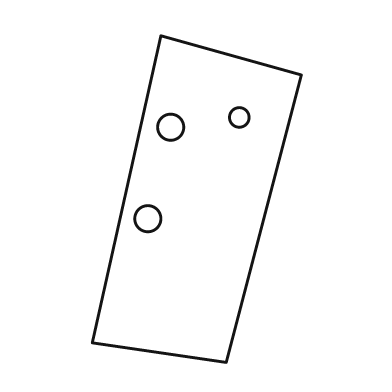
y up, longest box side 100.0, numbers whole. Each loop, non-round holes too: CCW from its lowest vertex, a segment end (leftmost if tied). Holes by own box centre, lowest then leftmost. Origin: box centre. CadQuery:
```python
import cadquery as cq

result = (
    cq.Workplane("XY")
    .moveTo(9.0, -50.0)
    .lineTo(32.0, 38.0)
    .lineTo(-11.0, 50.0)
    .lineTo(-32.0, -44.0)
    .close()
    .moveTo(-15.0, -6.0)
    .circle(4.0)
    .moveTo(-8.0, 22.0)
    .circle(4.0)
    .moveTo(13.0, 25.0)
    .circle(3.0)
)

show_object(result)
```